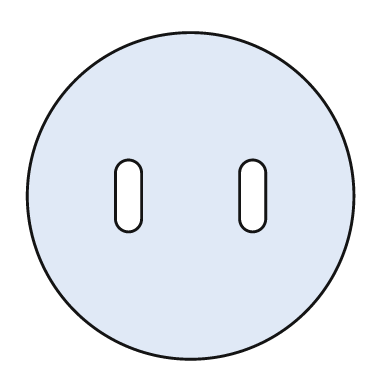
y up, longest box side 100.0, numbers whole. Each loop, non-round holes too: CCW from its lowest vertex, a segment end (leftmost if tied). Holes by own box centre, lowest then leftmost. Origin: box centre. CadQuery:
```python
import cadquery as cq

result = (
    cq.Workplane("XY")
    .moveTo(0.0, 0.0)
    .circle(50.0)
    .moveTo(-23.0, -7.0)
    .threePointArc((-19.0, -11.0), (-15.0, -7.0))
    .lineTo(-15.0, 7.0)
    .threePointArc((-19.0, 11.0), (-23.0, 7.0))
    .close()
    .moveTo(15.0, -7.0)
    .threePointArc((19.0, -11.0), (23.0, -7.0))
    .lineTo(23.0, 7.0)
    .threePointArc((19.0, 11.0), (15.0, 7.0))
    .close()
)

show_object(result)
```